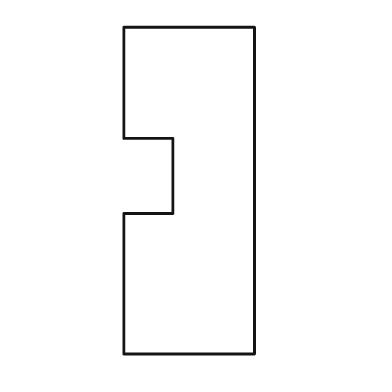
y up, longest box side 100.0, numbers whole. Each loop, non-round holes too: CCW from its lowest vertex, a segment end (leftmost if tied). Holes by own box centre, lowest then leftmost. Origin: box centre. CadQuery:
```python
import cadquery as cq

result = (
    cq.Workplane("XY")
    .moveTo(-20.0, -50.0)
    .lineTo(20.0, -50.0)
    .lineTo(20.0, 50.0)
    .lineTo(-20.0, 50.0)
    .lineTo(-20.0, 16.0)
    .lineTo(-5.0, 16.0)
    .lineTo(-5.0, -7.0)
    .lineTo(-20.0, -7.0)
    .close()
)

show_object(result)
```